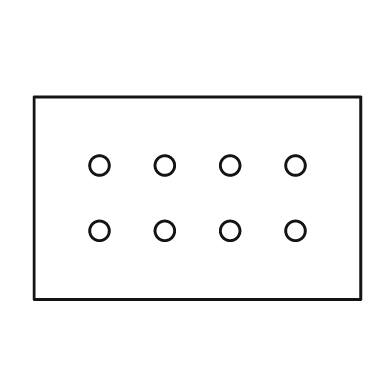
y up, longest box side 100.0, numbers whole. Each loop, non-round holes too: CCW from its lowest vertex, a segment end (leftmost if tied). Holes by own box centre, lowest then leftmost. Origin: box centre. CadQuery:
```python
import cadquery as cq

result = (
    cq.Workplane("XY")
    .moveTo(-50.0, -31.0)
    .lineTo(50.0, -31.0)
    .lineTo(50.0, 31.0)
    .lineTo(-50.0, 31.0)
    .close()
    .moveTo(-30.0, -10.0)
    .circle(3.0)
    .moveTo(-10.0, -10.0)
    .circle(3.0)
    .moveTo(10.0, -10.0)
    .circle(3.0)
    .moveTo(30.0, -10.0)
    .circle(3.0)
    .moveTo(-30.0, 10.0)
    .circle(3.0)
    .moveTo(-10.0, 10.0)
    .circle(3.0)
    .moveTo(10.0, 10.0)
    .circle(3.0)
    .moveTo(30.0, 10.0)
    .circle(3.0)
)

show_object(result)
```